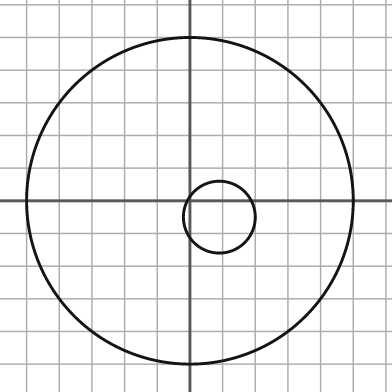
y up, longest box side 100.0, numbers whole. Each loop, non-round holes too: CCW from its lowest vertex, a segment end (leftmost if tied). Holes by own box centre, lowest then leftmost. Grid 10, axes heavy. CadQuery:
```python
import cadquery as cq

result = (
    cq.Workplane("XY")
    .moveTo(0.0, 0.0)
    .circle(50.0)
    .moveTo(9.0, -5.0)
    .circle(11.0)
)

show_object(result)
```